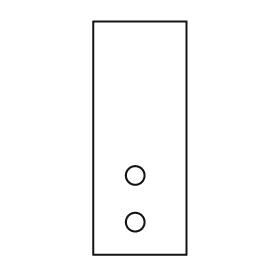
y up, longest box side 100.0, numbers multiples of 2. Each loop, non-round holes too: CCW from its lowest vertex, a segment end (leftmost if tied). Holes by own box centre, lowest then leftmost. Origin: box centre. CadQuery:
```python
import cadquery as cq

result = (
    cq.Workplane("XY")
    .moveTo(-20.0, -50.0)
    .lineTo(20.0, -50.0)
    .lineTo(20.0, 50.0)
    .lineTo(-20.0, 50.0)
    .close()
    .moveTo(-2.0, -36.0)
    .circle(4.0)
    .moveTo(-2.0, -16.0)
    .circle(4.0)
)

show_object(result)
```